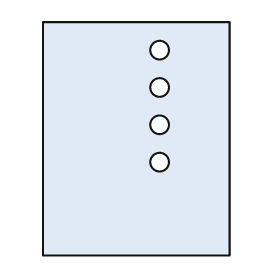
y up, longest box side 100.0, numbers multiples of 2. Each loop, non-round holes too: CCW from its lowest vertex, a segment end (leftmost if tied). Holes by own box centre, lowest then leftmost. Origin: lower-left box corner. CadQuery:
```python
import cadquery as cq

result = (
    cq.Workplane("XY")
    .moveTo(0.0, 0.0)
    .lineTo(80.0, 0.0)
    .lineTo(80.0, 100.0)
    .lineTo(0.0, 100.0)
    .close()
    .moveTo(50.0, 40.0)
    .circle(4.0)
    .moveTo(50.0, 56.0)
    .circle(4.0)
    .moveTo(50.0, 72.0)
    .circle(4.0)
    .moveTo(50.0, 88.0)
    .circle(4.0)
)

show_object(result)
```